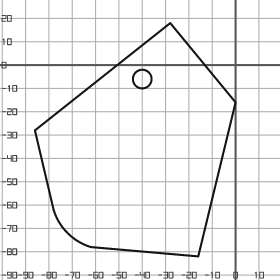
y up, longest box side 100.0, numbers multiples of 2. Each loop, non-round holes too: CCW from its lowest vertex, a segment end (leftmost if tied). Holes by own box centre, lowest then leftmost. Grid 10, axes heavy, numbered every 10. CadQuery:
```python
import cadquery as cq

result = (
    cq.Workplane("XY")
    .moveTo(-16.0, -82.0)
    .lineTo(0.0, -16.0)
    .lineTo(-28.0, 18.0)
    .lineTo(-86.0, -28.0)
    .lineTo(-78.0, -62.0)
    .threePointArc((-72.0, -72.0), (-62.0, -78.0))
    .close()
    .moveTo(-40.0, -6.0)
    .circle(4.0)
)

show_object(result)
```